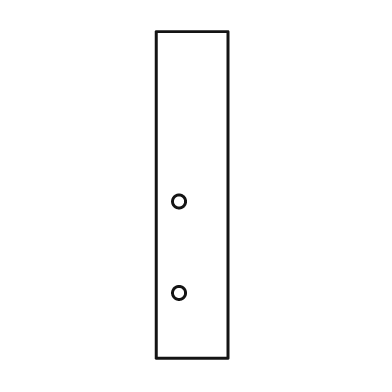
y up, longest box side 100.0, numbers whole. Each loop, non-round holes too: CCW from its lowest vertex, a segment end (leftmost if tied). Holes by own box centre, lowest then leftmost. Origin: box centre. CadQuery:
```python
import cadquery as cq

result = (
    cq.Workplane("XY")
    .moveTo(-11.0, -50.0)
    .lineTo(11.0, -50.0)
    .lineTo(11.0, 50.0)
    .lineTo(-11.0, 50.0)
    .close()
    .moveTo(-4.0, -30.0)
    .circle(2.0)
    .moveTo(-4.0, -2.0)
    .circle(2.0)
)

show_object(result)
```